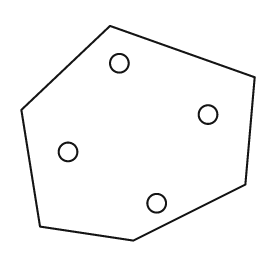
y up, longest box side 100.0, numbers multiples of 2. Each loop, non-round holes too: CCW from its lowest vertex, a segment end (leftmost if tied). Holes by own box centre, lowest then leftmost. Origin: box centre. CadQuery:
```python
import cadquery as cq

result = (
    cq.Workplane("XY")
    .moveTo(-2.0, -46.0)
    .lineTo(46.0, -22.0)
    .lineTo(50.0, 24.0)
    .lineTo(-12.0, 46.0)
    .lineTo(-50.0, 10.0)
    .lineTo(-42.0, -40.0)
    .close()
    .moveTo(8.0, -30.0)
    .circle(4.0)
    .moveTo(-30.0, -8.0)
    .circle(4.0)
    .moveTo(30.0, 8.0)
    .circle(4.0)
    .moveTo(-8.0, 30.0)
    .circle(4.0)
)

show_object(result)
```